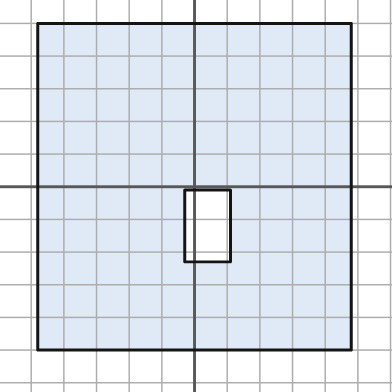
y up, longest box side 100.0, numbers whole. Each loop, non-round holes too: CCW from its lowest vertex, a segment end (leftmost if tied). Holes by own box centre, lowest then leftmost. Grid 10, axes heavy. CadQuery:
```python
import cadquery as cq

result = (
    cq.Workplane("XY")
    .moveTo(-48.0, -50.0)
    .lineTo(48.0, -50.0)
    .lineTo(48.0, 50.0)
    .lineTo(-48.0, 50.0)
    .close()
    .moveTo(-3.0, -23.0)
    .lineTo(11.0, -23.0)
    .lineTo(11.0, -1.0)
    .lineTo(-3.0, -1.0)
    .close()
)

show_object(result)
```